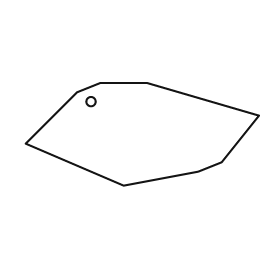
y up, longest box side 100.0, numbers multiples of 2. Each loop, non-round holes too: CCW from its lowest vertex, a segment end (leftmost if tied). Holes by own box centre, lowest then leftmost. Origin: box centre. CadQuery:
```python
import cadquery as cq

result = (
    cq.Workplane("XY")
    .moveTo(-8.0, -22.0)
    .lineTo(24.0, -16.0)
    .lineTo(34.0, -12.0)
    .lineTo(50.0, 8.0)
    .lineTo(2.0, 22.0)
    .lineTo(-18.0, 22.0)
    .lineTo(-28.0, 18.0)
    .lineTo(-50.0, -4.0)
    .close()
    .moveTo(-22.0, 14.0)
    .circle(2.0)
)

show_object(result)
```